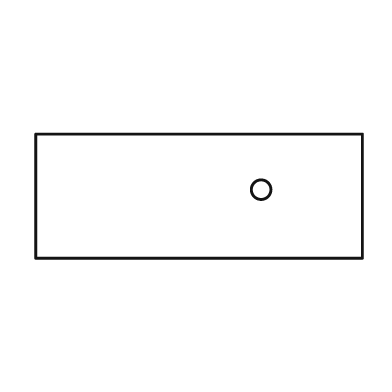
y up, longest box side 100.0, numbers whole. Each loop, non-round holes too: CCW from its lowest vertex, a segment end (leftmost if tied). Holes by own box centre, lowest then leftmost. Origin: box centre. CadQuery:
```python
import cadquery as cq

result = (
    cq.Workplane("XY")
    .moveTo(-50.0, -19.0)
    .lineTo(50.0, -19.0)
    .lineTo(50.0, 19.0)
    .lineTo(-50.0, 19.0)
    .close()
    .moveTo(19.0, 2.0)
    .circle(3.0)
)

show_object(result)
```